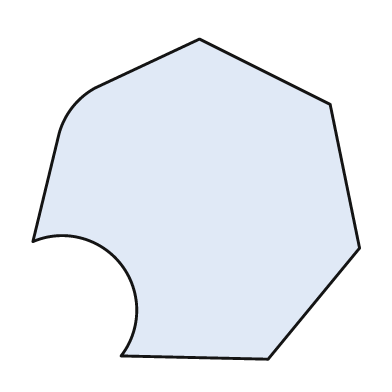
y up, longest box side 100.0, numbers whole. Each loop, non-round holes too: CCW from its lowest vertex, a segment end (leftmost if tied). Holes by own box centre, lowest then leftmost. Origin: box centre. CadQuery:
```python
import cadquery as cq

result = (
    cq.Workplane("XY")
    .moveTo(22.0, -49.0)
    .lineTo(50.0, -15.0)
    .lineTo(41.0, 29.0)
    .lineTo(1.0, 49.0)
    .lineTo(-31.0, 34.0)
    .threePointArc((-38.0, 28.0), (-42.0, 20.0))
    .lineTo(-50.0, -13.0)
    .threePointArc((-23.0, -20.0), (-23.0, -48.0))
    .close()
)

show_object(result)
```